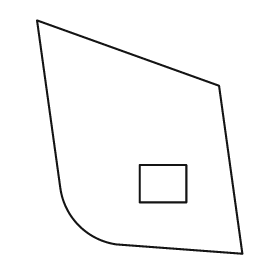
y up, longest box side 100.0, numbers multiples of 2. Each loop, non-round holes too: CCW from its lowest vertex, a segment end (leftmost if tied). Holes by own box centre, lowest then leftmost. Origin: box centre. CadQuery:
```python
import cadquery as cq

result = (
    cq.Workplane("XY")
    .moveTo(44.0, -50.0)
    .lineTo(34.0, 22.0)
    .lineTo(-44.0, 50.0)
    .lineTo(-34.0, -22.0)
    .threePointArc((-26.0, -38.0), (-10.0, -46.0))
    .close()
    .moveTo(0.0, -28.0)
    .lineTo(20.0, -28.0)
    .lineTo(20.0, -12.0)
    .lineTo(0.0, -12.0)
    .close()
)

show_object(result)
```